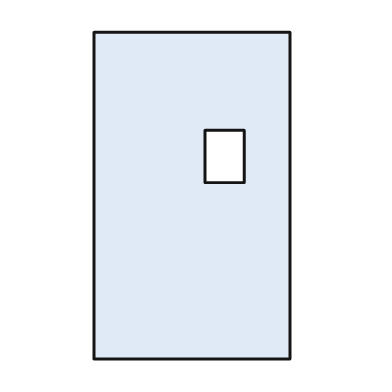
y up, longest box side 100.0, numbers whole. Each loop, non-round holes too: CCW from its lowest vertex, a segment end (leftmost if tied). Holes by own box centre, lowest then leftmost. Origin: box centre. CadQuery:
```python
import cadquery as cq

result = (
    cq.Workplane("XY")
    .moveTo(-30.0, -50.0)
    .lineTo(30.0, -50.0)
    .lineTo(30.0, 50.0)
    .lineTo(-30.0, 50.0)
    .close()
    .moveTo(4.0, 4.0)
    .lineTo(16.0, 4.0)
    .lineTo(16.0, 20.0)
    .lineTo(4.0, 20.0)
    .close()
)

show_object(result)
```